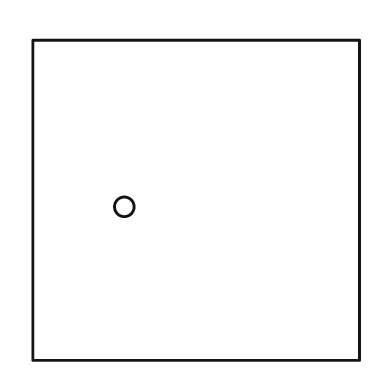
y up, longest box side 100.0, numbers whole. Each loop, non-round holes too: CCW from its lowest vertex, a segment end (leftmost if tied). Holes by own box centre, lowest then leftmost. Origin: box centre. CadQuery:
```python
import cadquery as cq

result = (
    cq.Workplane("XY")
    .moveTo(-50.0, -49.0)
    .lineTo(50.0, -49.0)
    .lineTo(50.0, 49.0)
    .lineTo(-50.0, 49.0)
    .close()
    .moveTo(-22.0, -2.0)
    .circle(3.0)
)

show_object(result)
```